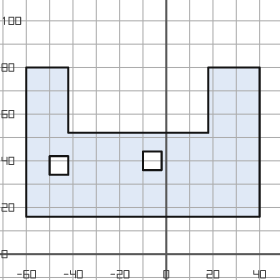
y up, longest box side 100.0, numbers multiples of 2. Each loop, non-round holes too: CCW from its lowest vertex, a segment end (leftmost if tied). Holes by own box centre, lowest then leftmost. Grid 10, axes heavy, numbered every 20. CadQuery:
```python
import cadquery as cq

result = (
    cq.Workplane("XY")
    .moveTo(-60.0, 16.0)
    .lineTo(40.0, 16.0)
    .lineTo(40.0, 80.0)
    .lineTo(18.0, 80.0)
    .lineTo(18.0, 52.0)
    .lineTo(-42.0, 52.0)
    .lineTo(-42.0, 80.0)
    .lineTo(-60.0, 80.0)
    .close()
    .moveTo(-50.0, 34.0)
    .lineTo(-42.0, 34.0)
    .lineTo(-42.0, 42.0)
    .lineTo(-50.0, 42.0)
    .close()
    .moveTo(-10.0, 36.0)
    .lineTo(-2.0, 36.0)
    .lineTo(-2.0, 44.0)
    .lineTo(-10.0, 44.0)
    .close()
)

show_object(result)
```